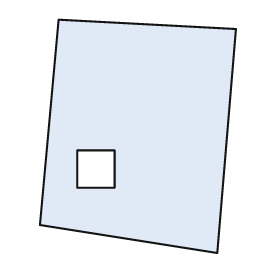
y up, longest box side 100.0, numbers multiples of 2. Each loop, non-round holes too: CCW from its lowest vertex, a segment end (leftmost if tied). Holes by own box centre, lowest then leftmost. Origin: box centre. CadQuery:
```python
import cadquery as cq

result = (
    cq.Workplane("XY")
    .moveTo(34.0, -50.0)
    .lineTo(42.0, 46.0)
    .lineTo(-34.0, 50.0)
    .lineTo(-42.0, -38.0)
    .close()
    .moveTo(-26.0, -22.0)
    .lineTo(-10.0, -22.0)
    .lineTo(-10.0, -6.0)
    .lineTo(-26.0, -6.0)
    .close()
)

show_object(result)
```